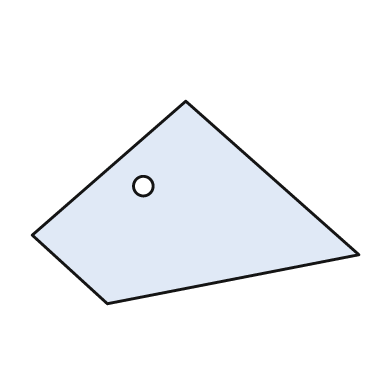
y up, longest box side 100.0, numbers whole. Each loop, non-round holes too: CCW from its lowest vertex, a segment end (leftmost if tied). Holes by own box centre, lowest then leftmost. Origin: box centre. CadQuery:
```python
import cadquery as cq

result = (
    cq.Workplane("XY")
    .moveTo(-27.0, -31.0)
    .lineTo(50.0, -16.0)
    .lineTo(-3.0, 31.0)
    .lineTo(-50.0, -10.0)
    .close()
    .moveTo(-16.0, 5.0)
    .circle(3.0)
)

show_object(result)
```